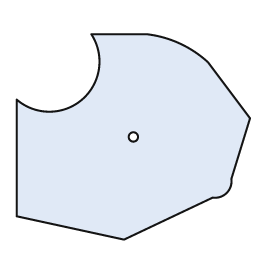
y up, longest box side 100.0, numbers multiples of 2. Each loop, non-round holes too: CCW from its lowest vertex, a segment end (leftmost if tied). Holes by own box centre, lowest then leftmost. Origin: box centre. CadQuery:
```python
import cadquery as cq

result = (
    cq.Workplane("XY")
    .moveTo(-4.0, -44.0)
    .lineTo(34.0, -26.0)
    .threePointArc((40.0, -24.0), (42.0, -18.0))
    .lineTo(50.0, 8.0)
    .lineTo(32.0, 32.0)
    .threePointArc((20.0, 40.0), (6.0, 44.0))
    .lineTo(-18.0, 44.0)
    .threePointArc((-22.0, 16.0), (-50.0, 16.0))
    .lineTo(-50.0, -34.0)
    .close()
    .moveTo(0.0, 0.0)
    .circle(2.0)
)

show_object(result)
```